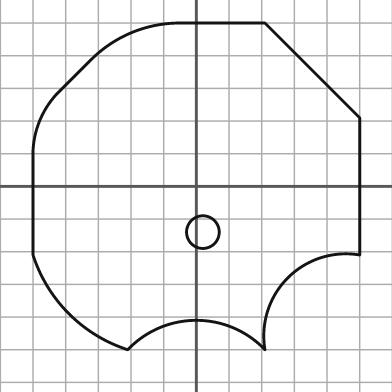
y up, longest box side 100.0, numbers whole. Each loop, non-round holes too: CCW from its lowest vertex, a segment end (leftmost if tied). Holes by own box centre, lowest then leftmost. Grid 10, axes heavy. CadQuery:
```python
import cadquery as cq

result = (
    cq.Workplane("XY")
    .moveTo(-21.0, -50.0)
    .threePointArc((0.0, -41.0), (21.0, -50.0))
    .threePointArc((28.0, -28.0), (50.0, -21.0))
    .lineTo(50.0, 21.0)
    .lineTo(21.0, 50.0)
    .lineTo(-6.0, 50.0)
    .threePointArc((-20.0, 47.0), (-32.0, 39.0))
    .lineTo(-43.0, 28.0)
    .threePointArc((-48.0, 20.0), (-50.0, 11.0))
    .lineTo(-50.0, -21.0)
    .threePointArc((-39.0, -39.0), (-21.0, -50.0))
    .close()
    .moveTo(2.0, -14.0)
    .circle(5.0)
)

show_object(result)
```